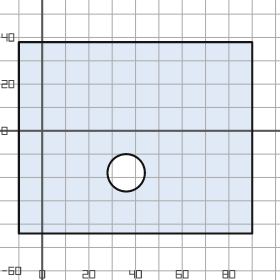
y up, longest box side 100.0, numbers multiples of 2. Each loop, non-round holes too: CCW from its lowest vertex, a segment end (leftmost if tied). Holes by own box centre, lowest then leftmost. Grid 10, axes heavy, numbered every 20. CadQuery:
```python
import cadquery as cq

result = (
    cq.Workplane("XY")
    .moveTo(-10.0, -44.0)
    .lineTo(90.0, -44.0)
    .lineTo(90.0, 38.0)
    .lineTo(-10.0, 38.0)
    .close()
    .moveTo(36.0, -18.0)
    .circle(8.0)
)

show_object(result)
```